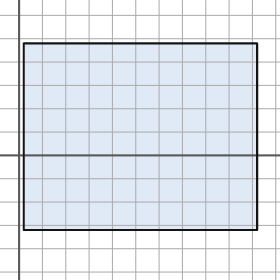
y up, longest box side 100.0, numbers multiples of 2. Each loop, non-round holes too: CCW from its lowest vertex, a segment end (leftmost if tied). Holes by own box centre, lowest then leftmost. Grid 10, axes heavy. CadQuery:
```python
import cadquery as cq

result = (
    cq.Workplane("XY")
    .moveTo(2.0, -32.0)
    .lineTo(102.0, -32.0)
    .lineTo(102.0, 48.0)
    .lineTo(2.0, 48.0)
    .close()
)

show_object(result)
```